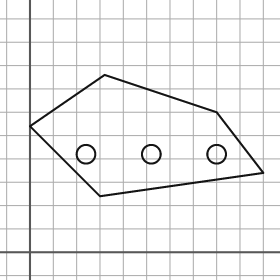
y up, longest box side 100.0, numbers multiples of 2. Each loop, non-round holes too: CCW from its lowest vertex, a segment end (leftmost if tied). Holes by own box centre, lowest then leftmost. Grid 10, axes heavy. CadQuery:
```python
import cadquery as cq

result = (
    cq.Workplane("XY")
    .moveTo(30.0, 24.0)
    .lineTo(100.0, 34.0)
    .lineTo(80.0, 60.0)
    .lineTo(32.0, 76.0)
    .lineTo(0.0, 54.0)
    .close()
    .moveTo(24.0, 42.0)
    .circle(4.0)
    .moveTo(52.0, 42.0)
    .circle(4.0)
    .moveTo(80.0, 42.0)
    .circle(4.0)
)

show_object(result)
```